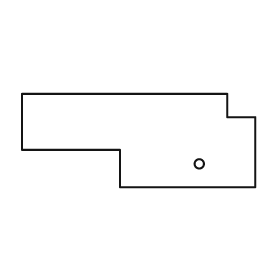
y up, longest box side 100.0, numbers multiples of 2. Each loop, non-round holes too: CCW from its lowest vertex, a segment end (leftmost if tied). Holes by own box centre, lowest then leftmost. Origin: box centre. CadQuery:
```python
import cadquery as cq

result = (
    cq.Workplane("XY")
    .moveTo(-8.0, -20.0)
    .lineTo(50.0, -20.0)
    .lineTo(50.0, 10.0)
    .lineTo(38.0, 10.0)
    .lineTo(38.0, 20.0)
    .lineTo(-50.0, 20.0)
    .lineTo(-50.0, -4.0)
    .lineTo(-8.0, -4.0)
    .close()
    .moveTo(26.0, -10.0)
    .circle(2.0)
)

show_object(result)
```